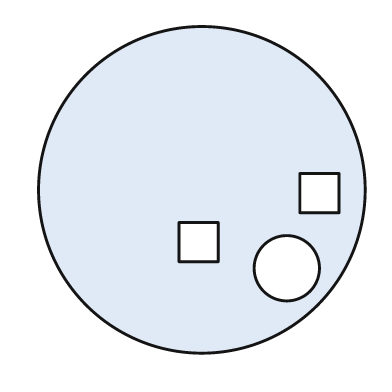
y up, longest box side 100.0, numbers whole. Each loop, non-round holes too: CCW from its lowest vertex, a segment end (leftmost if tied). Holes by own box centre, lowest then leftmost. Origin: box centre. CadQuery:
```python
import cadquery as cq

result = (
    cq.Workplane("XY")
    .moveTo(0.0, 0.0)
    .circle(50.0)
    .moveTo(26.0, -24.0)
    .circle(10.0)
    .moveTo(-7.0, -22.0)
    .lineTo(5.0, -22.0)
    .lineTo(5.0, -10.0)
    .lineTo(-7.0, -10.0)
    .close()
    .moveTo(30.0, -7.0)
    .lineTo(42.0, -7.0)
    .lineTo(42.0, 5.0)
    .lineTo(30.0, 5.0)
    .close()
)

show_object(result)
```